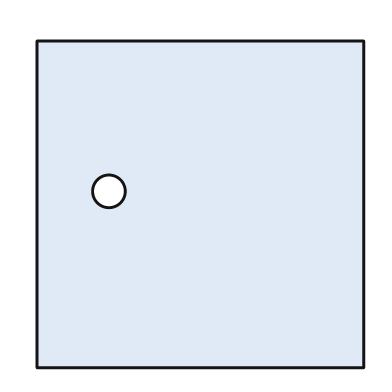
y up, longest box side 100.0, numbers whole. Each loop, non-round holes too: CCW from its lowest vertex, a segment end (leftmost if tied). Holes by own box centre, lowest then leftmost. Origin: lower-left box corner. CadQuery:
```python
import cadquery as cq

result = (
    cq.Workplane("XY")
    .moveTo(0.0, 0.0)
    .lineTo(100.0, 0.0)
    .lineTo(100.0, 100.0)
    .lineTo(0.0, 100.0)
    .close()
    .moveTo(22.0, 54.0)
    .circle(5.0)
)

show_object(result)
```